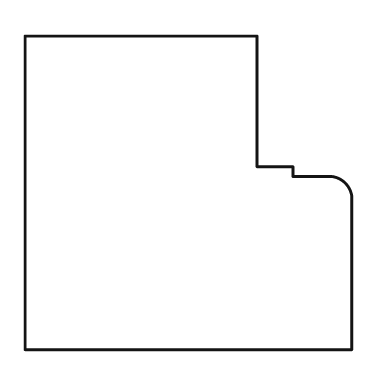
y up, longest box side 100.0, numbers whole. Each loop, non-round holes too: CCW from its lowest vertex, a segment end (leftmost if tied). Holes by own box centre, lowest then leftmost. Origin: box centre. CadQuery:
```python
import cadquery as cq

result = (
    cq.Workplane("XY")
    .moveTo(-50.0, -48.0)
    .lineTo(50.0, -48.0)
    .lineTo(50.0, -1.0)
    .threePointArc((48.0, 3.0), (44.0, 5.0))
    .lineTo(32.0, 5.0)
    .lineTo(32.0, 8.0)
    .lineTo(21.0, 8.0)
    .lineTo(21.0, 48.0)
    .lineTo(-50.0, 48.0)
    .close()
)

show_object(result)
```